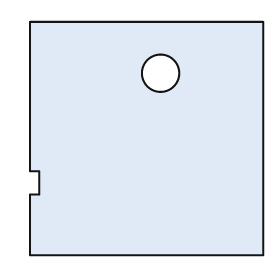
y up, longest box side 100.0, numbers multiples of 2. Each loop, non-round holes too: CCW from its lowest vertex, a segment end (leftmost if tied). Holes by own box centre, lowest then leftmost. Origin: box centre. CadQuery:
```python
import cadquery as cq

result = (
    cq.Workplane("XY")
    .moveTo(-50.0, -50.0)
    .lineTo(50.0, -50.0)
    .lineTo(50.0, 50.0)
    .lineTo(-50.0, 50.0)
    .lineTo(-50.0, -14.0)
    .lineTo(-46.0, -14.0)
    .lineTo(-46.0, -24.0)
    .lineTo(-50.0, -24.0)
    .close()
    .moveTo(6.0, 28.0)
    .circle(8.0)
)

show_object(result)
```